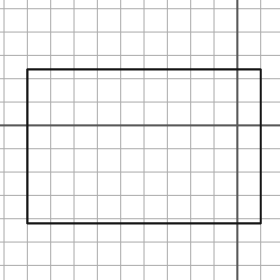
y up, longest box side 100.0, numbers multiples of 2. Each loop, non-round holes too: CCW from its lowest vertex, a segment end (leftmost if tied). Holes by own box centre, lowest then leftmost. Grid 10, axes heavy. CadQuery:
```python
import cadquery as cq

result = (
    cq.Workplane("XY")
    .moveTo(-90.0, -42.0)
    .lineTo(10.0, -42.0)
    .lineTo(10.0, 24.0)
    .lineTo(-90.0, 24.0)
    .close()
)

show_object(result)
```